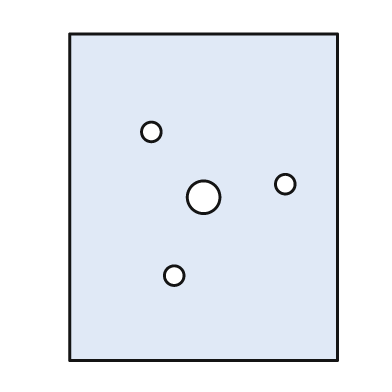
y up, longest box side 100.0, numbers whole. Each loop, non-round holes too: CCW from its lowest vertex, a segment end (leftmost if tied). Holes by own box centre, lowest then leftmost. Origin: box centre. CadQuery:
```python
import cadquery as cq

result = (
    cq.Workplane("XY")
    .moveTo(-41.0, -50.0)
    .lineTo(41.0, -50.0)
    .lineTo(41.0, 50.0)
    .lineTo(-41.0, 50.0)
    .close()
    .moveTo(-9.0, -24.0)
    .circle(3.0)
    .moveTo(0.0, 0.0)
    .circle(5.0)
    .moveTo(25.0, 4.0)
    .circle(3.0)
    .moveTo(-16.0, 20.0)
    .circle(3.0)
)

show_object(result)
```